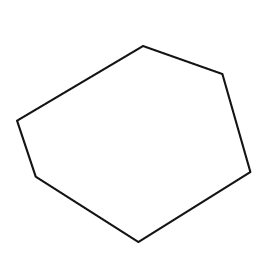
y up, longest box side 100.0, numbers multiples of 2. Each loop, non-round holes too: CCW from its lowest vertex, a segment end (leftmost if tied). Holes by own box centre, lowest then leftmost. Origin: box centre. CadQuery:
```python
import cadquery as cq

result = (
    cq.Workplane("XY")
    .moveTo(2.0, -42.0)
    .lineTo(50.0, -12.0)
    .lineTo(38.0, 30.0)
    .lineTo(4.0, 42.0)
    .lineTo(-50.0, 10.0)
    .lineTo(-42.0, -14.0)
    .close()
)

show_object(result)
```